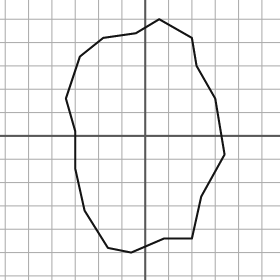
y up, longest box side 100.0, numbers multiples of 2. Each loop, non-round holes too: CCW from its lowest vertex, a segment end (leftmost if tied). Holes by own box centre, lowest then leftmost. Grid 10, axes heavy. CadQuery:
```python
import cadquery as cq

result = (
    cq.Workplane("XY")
    .moveTo(-6.0, -50.0)
    .lineTo(8.0, -44.0)
    .lineTo(20.0, -44.0)
    .lineTo(24.0, -26.0)
    .lineTo(34.0, -8.0)
    .lineTo(30.0, 16.0)
    .lineTo(22.0, 30.0)
    .lineTo(20.0, 42.0)
    .lineTo(6.0, 50.0)
    .lineTo(-4.0, 44.0)
    .lineTo(-18.0, 42.0)
    .lineTo(-28.0, 34.0)
    .lineTo(-34.0, 16.0)
    .lineTo(-30.0, 2.0)
    .lineTo(-30.0, -14.0)
    .lineTo(-26.0, -32.0)
    .lineTo(-16.0, -48.0)
    .close()
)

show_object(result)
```